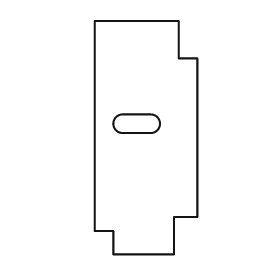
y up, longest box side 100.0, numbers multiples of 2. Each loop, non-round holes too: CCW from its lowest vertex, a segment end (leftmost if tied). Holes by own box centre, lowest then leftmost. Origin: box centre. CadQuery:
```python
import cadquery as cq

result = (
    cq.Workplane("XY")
    .moveTo(-14.0, -50.0)
    .lineTo(12.0, -50.0)
    .lineTo(12.0, -34.0)
    .lineTo(22.0, -34.0)
    .lineTo(22.0, 34.0)
    .lineTo(14.0, 34.0)
    .lineTo(14.0, 50.0)
    .lineTo(-22.0, 50.0)
    .lineTo(-22.0, -40.0)
    .lineTo(-14.0, -40.0)
    .close()
    .moveTo(-10.0, 2.0)
    .lineTo(2.0, 2.0)
    .threePointArc((6.0, 6.0), (2.0, 10.0))
    .lineTo(-10.0, 10.0)
    .threePointArc((-14.0, 6.0), (-10.0, 2.0))
    .close()
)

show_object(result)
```